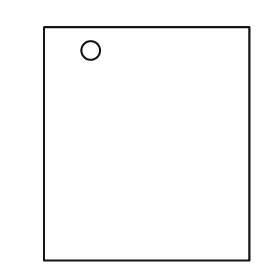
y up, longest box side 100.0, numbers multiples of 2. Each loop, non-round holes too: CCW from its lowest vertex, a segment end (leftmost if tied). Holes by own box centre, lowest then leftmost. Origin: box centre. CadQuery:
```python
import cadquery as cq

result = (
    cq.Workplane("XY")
    .moveTo(-44.0, -50.0)
    .lineTo(44.0, -50.0)
    .lineTo(44.0, 50.0)
    .lineTo(-44.0, 50.0)
    .close()
    .moveTo(-24.0, 40.0)
    .circle(4.0)
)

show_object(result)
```